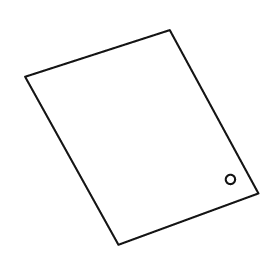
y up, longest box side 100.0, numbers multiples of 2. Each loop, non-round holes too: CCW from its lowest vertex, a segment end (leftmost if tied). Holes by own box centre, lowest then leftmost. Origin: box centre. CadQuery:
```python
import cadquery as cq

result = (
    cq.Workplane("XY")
    .moveTo(-10.0, -46.0)
    .lineTo(50.0, -24.0)
    .lineTo(12.0, 46.0)
    .lineTo(-50.0, 26.0)
    .close()
    .moveTo(38.0, -18.0)
    .circle(2.0)
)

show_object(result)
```